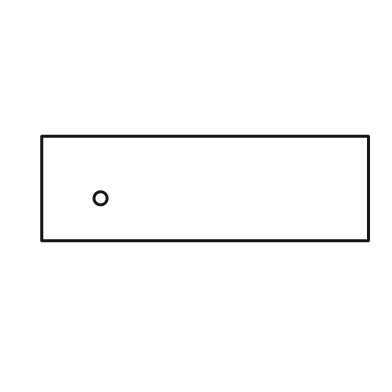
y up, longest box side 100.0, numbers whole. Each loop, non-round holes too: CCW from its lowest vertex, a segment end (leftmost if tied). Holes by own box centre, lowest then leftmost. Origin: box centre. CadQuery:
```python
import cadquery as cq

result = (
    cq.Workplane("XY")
    .moveTo(-50.0, -16.0)
    .lineTo(50.0, -16.0)
    .lineTo(50.0, 16.0)
    .lineTo(-50.0, 16.0)
    .close()
    .moveTo(-32.0, -3.0)
    .circle(2.0)
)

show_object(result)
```